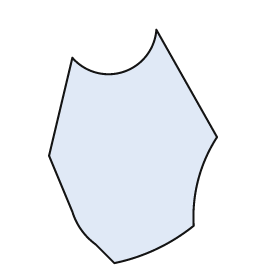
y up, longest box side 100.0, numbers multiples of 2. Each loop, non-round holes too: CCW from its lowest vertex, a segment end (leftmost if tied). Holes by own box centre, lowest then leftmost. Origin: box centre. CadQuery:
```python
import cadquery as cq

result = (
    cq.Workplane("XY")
    .moveTo(-8.0, -50.0)
    .threePointArc((10.0, -44.0), (26.0, -34.0))
    .threePointArc((28.0, -14.0), (36.0, 4.0))
    .lineTo(10.0, 50.0)
    .threePointArc((-4.0, 32.0), (-26.0, 38.0))
    .lineTo(-36.0, -4.0)
    .lineTo(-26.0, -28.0)
    .threePointArc((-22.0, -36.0), (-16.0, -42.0))
    .close()
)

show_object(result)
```